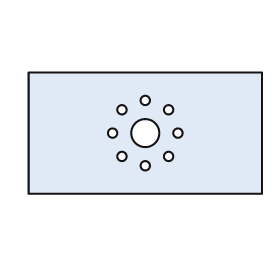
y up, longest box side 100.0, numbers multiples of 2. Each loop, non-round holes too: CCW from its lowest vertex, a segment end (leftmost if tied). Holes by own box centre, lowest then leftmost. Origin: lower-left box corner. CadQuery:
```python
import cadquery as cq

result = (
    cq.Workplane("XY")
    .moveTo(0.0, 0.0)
    .lineTo(100.0, 0.0)
    .lineTo(100.0, 52.0)
    .lineTo(0.0, 52.0)
    .close()
    .moveTo(50.0, 12.0)
    .circle(2.0)
    .moveTo(40.0, 16.0)
    .circle(2.0)
    .moveTo(60.0, 16.0)
    .circle(2.0)
    .moveTo(36.0, 26.0)
    .circle(2.0)
    .moveTo(50.0, 26.0)
    .circle(6.0)
    .moveTo(64.0, 26.0)
    .circle(2.0)
    .moveTo(40.0, 36.0)
    .circle(2.0)
    .moveTo(60.0, 36.0)
    .circle(2.0)
    .moveTo(50.0, 40.0)
    .circle(2.0)
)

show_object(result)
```